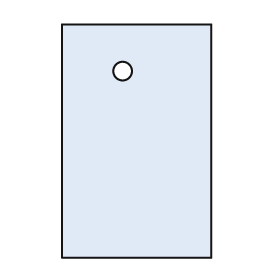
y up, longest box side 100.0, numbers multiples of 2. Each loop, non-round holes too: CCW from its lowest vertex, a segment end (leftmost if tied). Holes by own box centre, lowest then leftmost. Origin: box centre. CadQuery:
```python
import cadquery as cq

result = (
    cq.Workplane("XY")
    .moveTo(-32.0, -50.0)
    .lineTo(32.0, -50.0)
    .lineTo(32.0, 50.0)
    .lineTo(-32.0, 50.0)
    .close()
    .moveTo(-6.0, 30.0)
    .circle(4.0)
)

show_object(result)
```